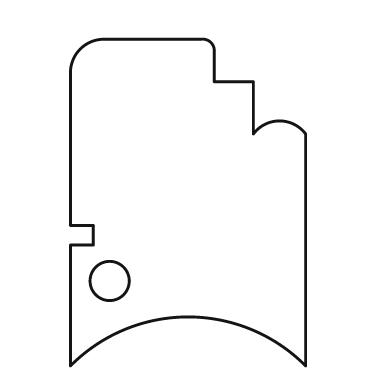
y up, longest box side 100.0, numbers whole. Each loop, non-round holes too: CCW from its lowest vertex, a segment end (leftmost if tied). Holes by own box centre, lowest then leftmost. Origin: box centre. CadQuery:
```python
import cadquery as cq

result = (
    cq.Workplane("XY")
    .moveTo(-36.0, -50.0)
    .threePointArc((0.0, -35.0), (36.0, -50.0))
    .lineTo(36.0, 21.0)
    .threePointArc((28.0, 25.0), (20.0, 21.0))
    .lineTo(20.0, 37.0)
    .lineTo(8.0, 37.0)
    .lineTo(8.0, 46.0)
    .threePointArc((7.0, 49.0), (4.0, 50.0))
    .lineTo(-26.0, 50.0)
    .threePointArc((-33.0, 47.0), (-36.0, 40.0))
    .lineTo(-36.0, -7.0)
    .lineTo(-29.0, -7.0)
    .lineTo(-29.0, -13.0)
    .lineTo(-36.0, -13.0)
    .close()
    .moveTo(-24.0, -24.0)
    .circle(6.0)
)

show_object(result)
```